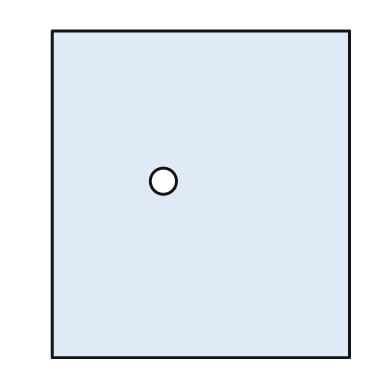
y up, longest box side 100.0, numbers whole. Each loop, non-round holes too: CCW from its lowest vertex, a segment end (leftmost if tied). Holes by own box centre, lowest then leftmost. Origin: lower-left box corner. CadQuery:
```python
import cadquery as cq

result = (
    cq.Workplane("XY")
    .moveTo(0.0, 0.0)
    .lineTo(91.0, 0.0)
    .lineTo(91.0, 100.0)
    .lineTo(0.0, 100.0)
    .close()
    .moveTo(34.0, 54.0)
    .circle(4.0)
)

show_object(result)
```